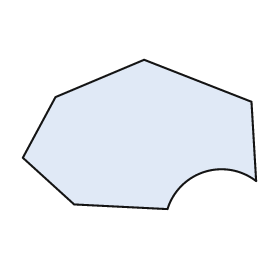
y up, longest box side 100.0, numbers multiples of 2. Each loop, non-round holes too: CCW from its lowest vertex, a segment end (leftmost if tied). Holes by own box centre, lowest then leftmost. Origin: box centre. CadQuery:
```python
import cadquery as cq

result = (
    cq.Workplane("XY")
    .moveTo(12.0, -32.0)
    .threePointArc((28.0, -16.0), (50.0, -20.0))
    .lineTo(48.0, 14.0)
    .lineTo(2.0, 32.0)
    .lineTo(-36.0, 16.0)
    .lineTo(-50.0, -10.0)
    .lineTo(-28.0, -30.0)
    .close()
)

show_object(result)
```